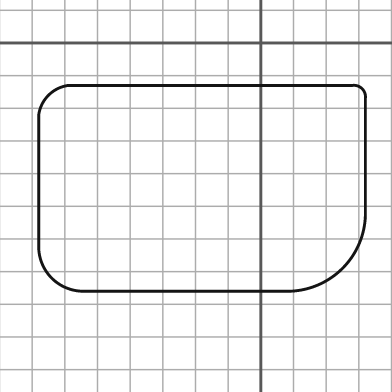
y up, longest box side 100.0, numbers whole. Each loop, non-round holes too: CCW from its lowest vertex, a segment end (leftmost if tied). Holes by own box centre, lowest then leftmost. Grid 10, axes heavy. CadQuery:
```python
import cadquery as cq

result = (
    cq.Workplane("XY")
    .moveTo(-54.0, -76.0)
    .lineTo(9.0, -76.0)
    .threePointArc((25.0, -69.0), (32.0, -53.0))
    .lineTo(32.0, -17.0)
    .threePointArc((31.0, -14.0), (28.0, -13.0))
    .lineTo(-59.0, -13.0)
    .threePointArc((-65.0, -16.0), (-68.0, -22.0))
    .lineTo(-68.0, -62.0)
    .threePointArc((-64.0, -72.0), (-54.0, -76.0))
    .close()
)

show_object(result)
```